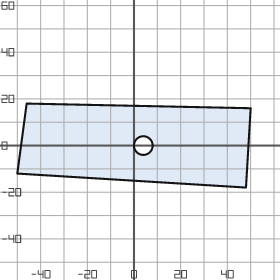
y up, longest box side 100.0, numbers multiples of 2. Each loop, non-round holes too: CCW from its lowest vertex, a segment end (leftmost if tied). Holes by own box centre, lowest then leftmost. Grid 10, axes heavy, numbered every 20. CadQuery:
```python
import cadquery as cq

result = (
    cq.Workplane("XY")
    .moveTo(48.0, -18.0)
    .lineTo(50.0, 16.0)
    .lineTo(-46.0, 18.0)
    .lineTo(-50.0, -12.0)
    .close()
    .moveTo(4.0, 0.0)
    .circle(4.0)
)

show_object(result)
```